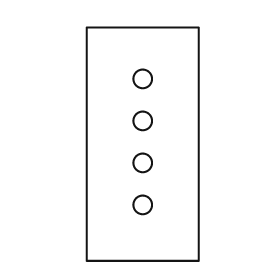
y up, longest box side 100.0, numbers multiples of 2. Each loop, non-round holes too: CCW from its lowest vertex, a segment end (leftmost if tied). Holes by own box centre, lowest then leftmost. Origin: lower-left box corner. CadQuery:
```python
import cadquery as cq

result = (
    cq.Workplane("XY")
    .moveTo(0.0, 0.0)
    .lineTo(48.0, 0.0)
    .lineTo(48.0, 100.0)
    .lineTo(0.0, 100.0)
    .close()
    .moveTo(24.0, 24.0)
    .circle(4.0)
    .moveTo(24.0, 42.0)
    .circle(4.0)
    .moveTo(24.0, 60.0)
    .circle(4.0)
    .moveTo(24.0, 78.0)
    .circle(4.0)
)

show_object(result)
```